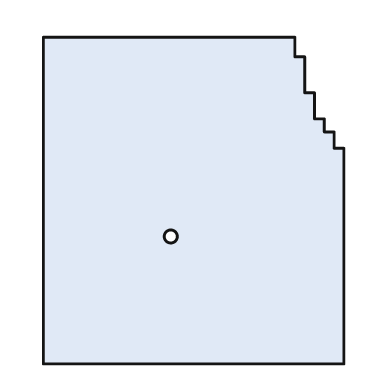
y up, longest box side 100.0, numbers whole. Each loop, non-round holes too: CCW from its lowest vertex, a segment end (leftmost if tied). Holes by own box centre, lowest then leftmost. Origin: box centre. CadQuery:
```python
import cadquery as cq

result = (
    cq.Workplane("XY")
    .moveTo(-46.0, -50.0)
    .lineTo(46.0, -50.0)
    .lineTo(46.0, 16.0)
    .lineTo(43.0, 16.0)
    .lineTo(43.0, 21.0)
    .lineTo(40.0, 21.0)
    .lineTo(40.0, 25.0)
    .lineTo(37.0, 25.0)
    .lineTo(37.0, 33.0)
    .lineTo(34.0, 33.0)
    .lineTo(34.0, 44.0)
    .lineTo(31.0, 44.0)
    .lineTo(31.0, 50.0)
    .lineTo(-46.0, 50.0)
    .close()
    .moveTo(-7.0, -11.0)
    .circle(2.0)
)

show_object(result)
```